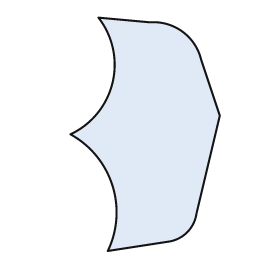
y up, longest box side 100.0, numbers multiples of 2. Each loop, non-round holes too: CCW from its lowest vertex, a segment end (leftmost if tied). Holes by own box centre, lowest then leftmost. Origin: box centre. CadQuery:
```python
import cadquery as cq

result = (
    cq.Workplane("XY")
    .moveTo(-16.0, -50.0)
    .lineTo(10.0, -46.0)
    .threePointArc((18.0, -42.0), (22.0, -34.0))
    .lineTo(32.0, 8.0)
    .lineTo(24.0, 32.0)
    .threePointArc((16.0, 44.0), (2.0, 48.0))
    .lineTo(-20.0, 50.0)
    .threePointArc((-14.0, 22.0), (-32.0, 0.0))
    .threePointArc((-14.0, -22.0), (-16.0, -50.0))
    .close()
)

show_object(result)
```